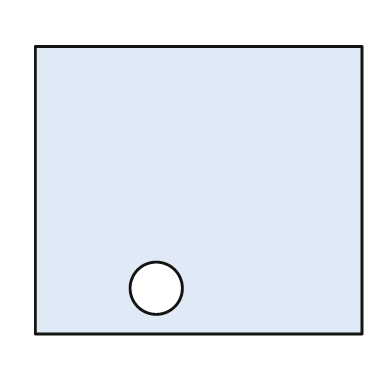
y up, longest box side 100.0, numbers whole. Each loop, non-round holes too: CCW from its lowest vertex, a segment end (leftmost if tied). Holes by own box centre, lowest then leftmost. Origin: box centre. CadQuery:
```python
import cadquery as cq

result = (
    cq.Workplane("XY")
    .moveTo(-50.0, -44.0)
    .lineTo(50.0, -44.0)
    .lineTo(50.0, 44.0)
    .lineTo(-50.0, 44.0)
    .close()
    .moveTo(-13.0, -30.0)
    .circle(8.0)
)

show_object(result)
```